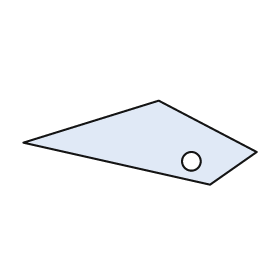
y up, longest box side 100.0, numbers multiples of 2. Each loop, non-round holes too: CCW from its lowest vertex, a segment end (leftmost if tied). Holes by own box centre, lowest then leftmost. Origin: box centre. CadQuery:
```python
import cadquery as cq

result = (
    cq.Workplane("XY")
    .moveTo(30.0, -18.0)
    .lineTo(50.0, -4.0)
    .lineTo(8.0, 18.0)
    .lineTo(-50.0, 0.0)
    .close()
    .moveTo(22.0, -8.0)
    .circle(4.0)
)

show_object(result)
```